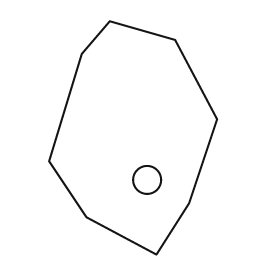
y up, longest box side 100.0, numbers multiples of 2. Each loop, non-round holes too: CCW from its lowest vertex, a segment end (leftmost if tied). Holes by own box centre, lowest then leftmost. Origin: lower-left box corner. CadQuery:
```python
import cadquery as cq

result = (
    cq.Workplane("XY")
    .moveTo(46.0, 0.0)
    .lineTo(60.0, 22.0)
    .lineTo(72.0, 58.0)
    .lineTo(54.0, 92.0)
    .lineTo(26.0, 100.0)
    .lineTo(14.0, 86.0)
    .lineTo(0.0, 40.0)
    .lineTo(16.0, 16.0)
    .close()
    .moveTo(42.0, 32.0)
    .circle(6.0)
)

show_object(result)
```